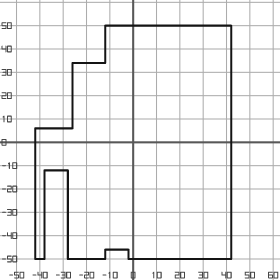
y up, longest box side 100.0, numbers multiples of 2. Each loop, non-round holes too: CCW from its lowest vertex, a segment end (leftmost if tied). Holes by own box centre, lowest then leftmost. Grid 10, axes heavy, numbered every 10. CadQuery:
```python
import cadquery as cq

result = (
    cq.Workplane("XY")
    .moveTo(-42.0, -50.0)
    .lineTo(-38.0, -50.0)
    .lineTo(-38.0, -12.0)
    .lineTo(-28.0, -12.0)
    .lineTo(-28.0, -50.0)
    .lineTo(-12.0, -50.0)
    .lineTo(-12.0, -46.0)
    .lineTo(-2.0, -46.0)
    .lineTo(-2.0, -50.0)
    .lineTo(42.0, -50.0)
    .lineTo(42.0, 50.0)
    .lineTo(-12.0, 50.0)
    .lineTo(-12.0, 34.0)
    .lineTo(-26.0, 34.0)
    .lineTo(-26.0, 6.0)
    .lineTo(-42.0, 6.0)
    .close()
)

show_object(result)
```